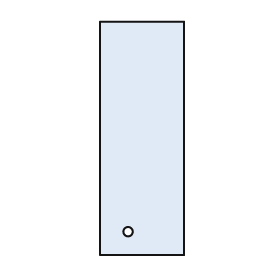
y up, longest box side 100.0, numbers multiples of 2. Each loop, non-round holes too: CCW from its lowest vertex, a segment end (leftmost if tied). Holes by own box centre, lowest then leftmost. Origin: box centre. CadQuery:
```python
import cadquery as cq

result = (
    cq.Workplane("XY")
    .moveTo(-18.0, -50.0)
    .lineTo(18.0, -50.0)
    .lineTo(18.0, 50.0)
    .lineTo(-18.0, 50.0)
    .close()
    .moveTo(-6.0, -40.0)
    .circle(2.0)
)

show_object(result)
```